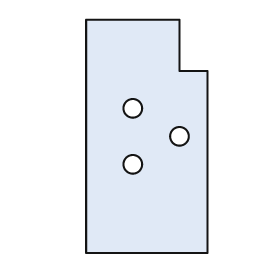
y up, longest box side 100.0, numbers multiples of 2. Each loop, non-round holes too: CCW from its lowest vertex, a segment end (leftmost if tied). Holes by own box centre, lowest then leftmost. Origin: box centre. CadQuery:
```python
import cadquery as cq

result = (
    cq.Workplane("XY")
    .moveTo(-26.0, -50.0)
    .lineTo(26.0, -50.0)
    .lineTo(26.0, 28.0)
    .lineTo(14.0, 28.0)
    .lineTo(14.0, 50.0)
    .lineTo(-26.0, 50.0)
    .close()
    .moveTo(-6.0, -12.0)
    .circle(4.0)
    .moveTo(14.0, 0.0)
    .circle(4.0)
    .moveTo(-6.0, 12.0)
    .circle(4.0)
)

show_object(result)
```